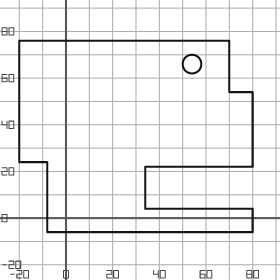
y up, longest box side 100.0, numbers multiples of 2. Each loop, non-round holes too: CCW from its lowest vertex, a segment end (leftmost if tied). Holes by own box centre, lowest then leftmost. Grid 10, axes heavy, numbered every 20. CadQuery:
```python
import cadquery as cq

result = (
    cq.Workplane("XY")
    .moveTo(-8.0, -6.0)
    .lineTo(80.0, -6.0)
    .lineTo(80.0, 4.0)
    .lineTo(34.0, 4.0)
    .lineTo(34.0, 22.0)
    .lineTo(80.0, 22.0)
    .lineTo(80.0, 54.0)
    .lineTo(70.0, 54.0)
    .lineTo(70.0, 76.0)
    .lineTo(-20.0, 76.0)
    .lineTo(-20.0, 24.0)
    .lineTo(-8.0, 24.0)
    .close()
    .moveTo(54.0, 66.0)
    .circle(4.0)
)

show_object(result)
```